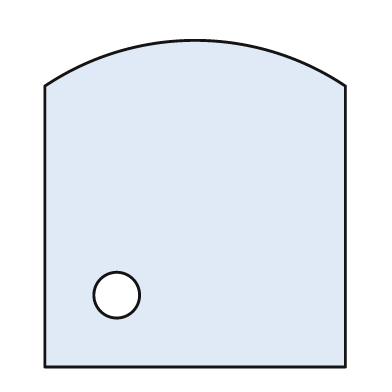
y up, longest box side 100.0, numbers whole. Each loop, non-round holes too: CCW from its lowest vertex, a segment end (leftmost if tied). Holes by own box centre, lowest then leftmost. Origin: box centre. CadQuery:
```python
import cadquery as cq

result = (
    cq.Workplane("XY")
    .moveTo(-46.0, -50.0)
    .lineTo(46.0, -50.0)
    .lineTo(46.0, 36.0)
    .threePointArc((0.0, 50.0), (-46.0, 36.0))
    .close()
    .moveTo(-24.0, -28.0)
    .circle(7.0)
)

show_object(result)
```